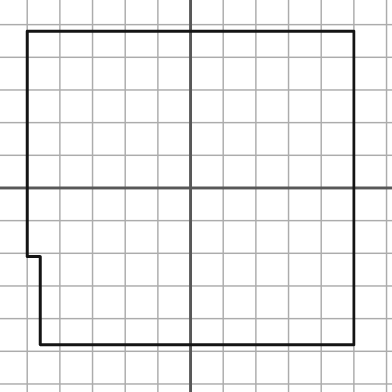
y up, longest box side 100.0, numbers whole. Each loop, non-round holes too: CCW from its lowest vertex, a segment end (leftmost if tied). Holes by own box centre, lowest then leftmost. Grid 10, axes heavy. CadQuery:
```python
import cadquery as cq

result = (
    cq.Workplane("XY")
    .moveTo(-46.0, -48.0)
    .lineTo(50.0, -48.0)
    .lineTo(50.0, 48.0)
    .lineTo(-50.0, 48.0)
    .lineTo(-50.0, -21.0)
    .lineTo(-46.0, -21.0)
    .close()
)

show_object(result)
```